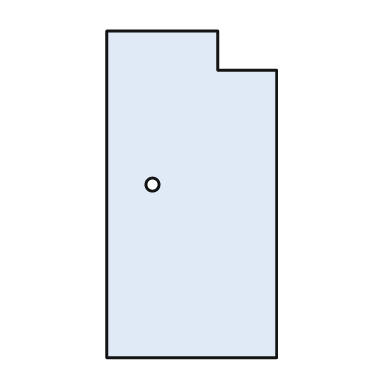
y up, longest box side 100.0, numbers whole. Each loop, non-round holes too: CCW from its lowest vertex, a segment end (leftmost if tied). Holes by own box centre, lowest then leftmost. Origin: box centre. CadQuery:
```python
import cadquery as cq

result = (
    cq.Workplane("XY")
    .moveTo(-26.0, -50.0)
    .lineTo(26.0, -50.0)
    .lineTo(26.0, 38.0)
    .lineTo(8.0, 38.0)
    .lineTo(8.0, 50.0)
    .lineTo(-26.0, 50.0)
    .close()
    .moveTo(-12.0, 3.0)
    .circle(2.0)
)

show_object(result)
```